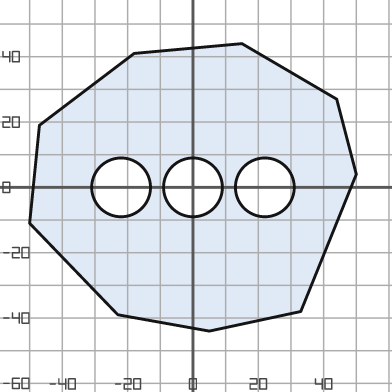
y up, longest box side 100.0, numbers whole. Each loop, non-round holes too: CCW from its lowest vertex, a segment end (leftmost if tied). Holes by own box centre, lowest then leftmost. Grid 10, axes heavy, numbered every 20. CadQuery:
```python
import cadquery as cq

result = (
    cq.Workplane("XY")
    .moveTo(5.0, -44.0)
    .lineTo(33.0, -38.0)
    .lineTo(50.0, 4.0)
    .lineTo(44.0, 27.0)
    .lineTo(15.0, 44.0)
    .lineTo(-18.0, 41.0)
    .lineTo(-47.0, 19.0)
    .lineTo(-50.0, -11.0)
    .lineTo(-23.0, -39.0)
    .close()
    .moveTo(-22.0, 0.0)
    .circle(9.0)
    .moveTo(0.0, 0.0)
    .circle(9.0)
    .moveTo(22.0, 0.0)
    .circle(9.0)
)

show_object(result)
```